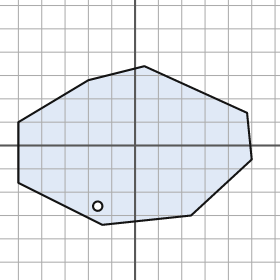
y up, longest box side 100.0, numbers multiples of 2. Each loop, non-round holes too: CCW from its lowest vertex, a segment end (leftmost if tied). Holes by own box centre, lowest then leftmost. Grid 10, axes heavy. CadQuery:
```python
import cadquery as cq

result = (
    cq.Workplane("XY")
    .moveTo(-14.0, -34.0)
    .lineTo(24.0, -30.0)
    .lineTo(50.0, -6.0)
    .lineTo(48.0, 14.0)
    .lineTo(4.0, 34.0)
    .lineTo(-20.0, 28.0)
    .lineTo(-50.0, 10.0)
    .lineTo(-50.0, -16.0)
    .close()
    .moveTo(-16.0, -26.0)
    .circle(2.0)
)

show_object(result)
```